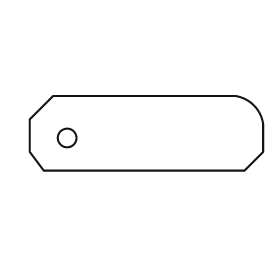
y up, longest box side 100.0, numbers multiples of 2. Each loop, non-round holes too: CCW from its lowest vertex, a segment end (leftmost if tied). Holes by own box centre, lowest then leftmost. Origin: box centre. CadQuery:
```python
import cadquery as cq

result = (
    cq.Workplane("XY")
    .moveTo(-44.0, -16.0)
    .lineTo(42.0, -16.0)
    .lineTo(50.0, -8.0)
    .lineTo(50.0, 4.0)
    .threePointArc((46.0, 12.0), (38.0, 16.0))
    .lineTo(-40.0, 16.0)
    .lineTo(-50.0, 6.0)
    .lineTo(-50.0, -8.0)
    .close()
    .moveTo(-34.0, -2.0)
    .circle(4.0)
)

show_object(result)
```